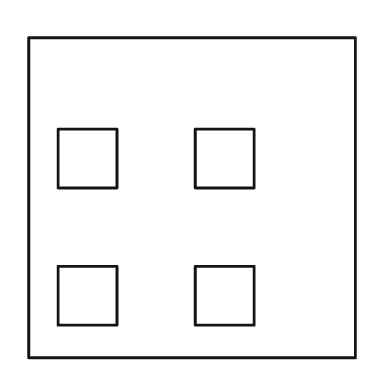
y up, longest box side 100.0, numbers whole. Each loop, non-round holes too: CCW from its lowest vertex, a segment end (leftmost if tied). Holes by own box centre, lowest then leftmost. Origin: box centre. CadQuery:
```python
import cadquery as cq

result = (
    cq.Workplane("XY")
    .moveTo(-50.0, -49.0)
    .lineTo(50.0, -49.0)
    .lineTo(50.0, 49.0)
    .lineTo(-50.0, 49.0)
    .close()
    .moveTo(-41.0, -39.0)
    .lineTo(-23.0, -39.0)
    .lineTo(-23.0, -21.0)
    .lineTo(-41.0, -21.0)
    .close()
    .moveTo(1.0, -39.0)
    .lineTo(19.0, -39.0)
    .lineTo(19.0, -21.0)
    .lineTo(1.0, -21.0)
    .close()
    .moveTo(-41.0, 3.0)
    .lineTo(-23.0, 3.0)
    .lineTo(-23.0, 21.0)
    .lineTo(-41.0, 21.0)
    .close()
    .moveTo(1.0, 3.0)
    .lineTo(19.0, 3.0)
    .lineTo(19.0, 21.0)
    .lineTo(1.0, 21.0)
    .close()
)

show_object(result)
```